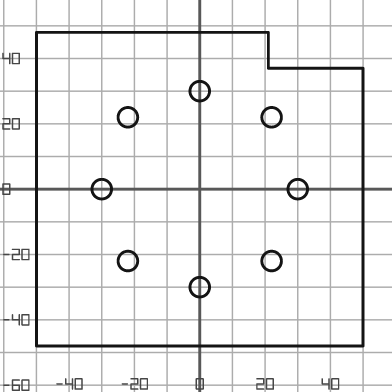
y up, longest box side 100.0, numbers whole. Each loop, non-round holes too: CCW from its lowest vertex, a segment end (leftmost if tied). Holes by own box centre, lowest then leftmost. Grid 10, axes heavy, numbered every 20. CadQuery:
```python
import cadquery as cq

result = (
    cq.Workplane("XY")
    .moveTo(-50.0, -48.0)
    .lineTo(50.0, -48.0)
    .lineTo(50.0, 37.0)
    .lineTo(21.0, 37.0)
    .lineTo(21.0, 48.0)
    .lineTo(-50.0, 48.0)
    .close()
    .moveTo(0.0, -30.0)
    .circle(3.0)
    .moveTo(-22.0, -22.0)
    .circle(3.0)
    .moveTo(22.0, -22.0)
    .circle(3.0)
    .moveTo(-30.0, 0.0)
    .circle(3.0)
    .moveTo(30.0, 0.0)
    .circle(3.0)
    .moveTo(-22.0, 22.0)
    .circle(3.0)
    .moveTo(22.0, 22.0)
    .circle(3.0)
    .moveTo(0.0, 30.0)
    .circle(3.0)
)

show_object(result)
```